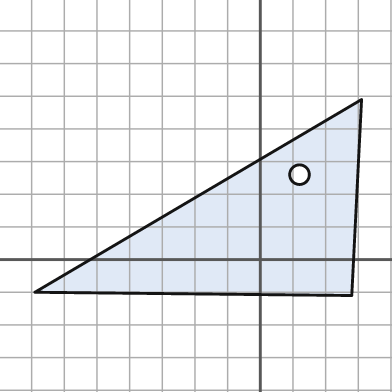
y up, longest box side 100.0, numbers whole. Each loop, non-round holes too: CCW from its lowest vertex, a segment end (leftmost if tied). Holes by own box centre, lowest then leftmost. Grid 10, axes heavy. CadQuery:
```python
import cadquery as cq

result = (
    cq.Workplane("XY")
    .moveTo(28.0, -11.0)
    .lineTo(31.0, 49.0)
    .lineTo(-69.0, -10.0)
    .close()
    .moveTo(12.0, 26.0)
    .circle(3.0)
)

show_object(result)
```